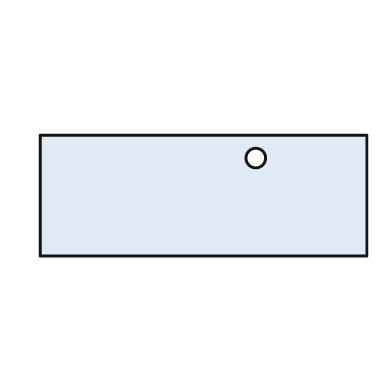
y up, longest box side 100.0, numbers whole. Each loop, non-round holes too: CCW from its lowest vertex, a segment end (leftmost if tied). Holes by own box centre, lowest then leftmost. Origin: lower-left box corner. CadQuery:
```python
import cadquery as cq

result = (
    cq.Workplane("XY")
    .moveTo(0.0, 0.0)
    .lineTo(100.0, 0.0)
    .lineTo(100.0, 37.0)
    .lineTo(0.0, 37.0)
    .close()
    .moveTo(66.0, 30.0)
    .circle(3.0)
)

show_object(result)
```